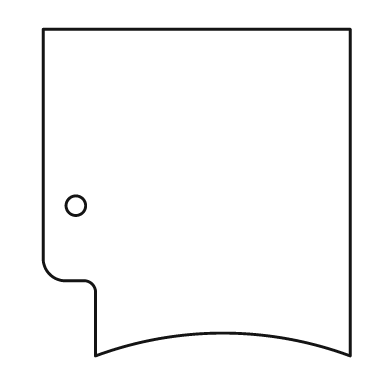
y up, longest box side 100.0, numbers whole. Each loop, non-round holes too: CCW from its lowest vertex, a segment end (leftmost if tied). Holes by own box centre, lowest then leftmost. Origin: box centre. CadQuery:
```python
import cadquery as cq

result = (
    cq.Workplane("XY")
    .moveTo(-31.0, -50.0)
    .threePointArc((8.0, -43.0), (47.0, -50.0))
    .lineTo(47.0, 50.0)
    .lineTo(-47.0, 50.0)
    .lineTo(-47.0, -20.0)
    .threePointArc((-45.0, -25.0), (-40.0, -27.0))
    .lineTo(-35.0, -27.0)
    .threePointArc((-32.0, -28.0), (-31.0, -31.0))
    .close()
    .moveTo(-37.0, -4.0)
    .circle(3.0)
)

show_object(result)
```